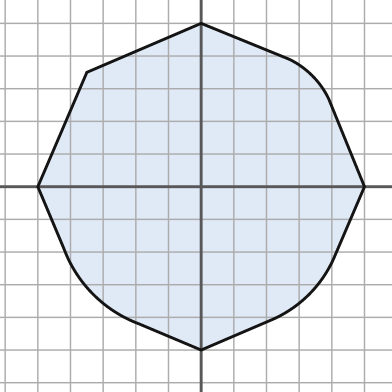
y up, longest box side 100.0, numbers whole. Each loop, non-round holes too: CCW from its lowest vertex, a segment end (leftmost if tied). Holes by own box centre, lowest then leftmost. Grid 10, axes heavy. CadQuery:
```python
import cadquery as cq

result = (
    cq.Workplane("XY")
    .moveTo(0.0, -50.0)
    .lineTo(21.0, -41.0)
    .threePointArc((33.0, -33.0), (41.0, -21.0))
    .lineTo(50.0, 0.0)
    .lineTo(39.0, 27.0)
    .threePointArc((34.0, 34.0), (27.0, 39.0))
    .lineTo(0.0, 50.0)
    .lineTo(-35.0, 35.0)
    .lineTo(-50.0, 0.0)
    .lineTo(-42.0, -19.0)
    .threePointArc((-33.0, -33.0), (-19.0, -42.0))
    .close()
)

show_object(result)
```